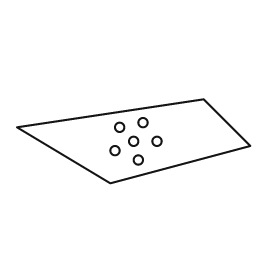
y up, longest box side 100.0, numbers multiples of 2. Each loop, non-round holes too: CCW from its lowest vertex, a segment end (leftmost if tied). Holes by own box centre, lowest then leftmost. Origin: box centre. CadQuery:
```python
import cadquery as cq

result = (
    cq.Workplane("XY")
    .moveTo(-10.0, -18.0)
    .lineTo(50.0, -2.0)
    .lineTo(30.0, 18.0)
    .lineTo(-50.0, 6.0)
    .close()
    .moveTo(2.0, -8.0)
    .circle(2.0)
    .moveTo(-8.0, -4.0)
    .circle(2.0)
    .moveTo(0.0, 0.0)
    .circle(2.0)
    .moveTo(10.0, 0.0)
    .circle(2.0)
    .moveTo(-6.0, 6.0)
    .circle(2.0)
    .moveTo(4.0, 8.0)
    .circle(2.0)
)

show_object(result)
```